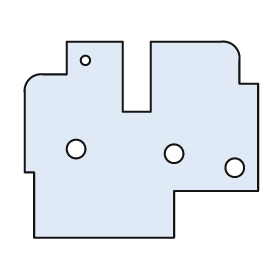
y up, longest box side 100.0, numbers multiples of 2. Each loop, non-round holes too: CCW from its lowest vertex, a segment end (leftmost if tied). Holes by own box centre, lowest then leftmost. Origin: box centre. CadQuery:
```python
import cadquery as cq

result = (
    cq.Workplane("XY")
    .moveTo(-46.0, -42.0)
    .lineTo(14.0, -42.0)
    .lineTo(14.0, -22.0)
    .lineTo(50.0, -22.0)
    .lineTo(50.0, 24.0)
    .lineTo(42.0, 24.0)
    .lineTo(42.0, 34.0)
    .threePointArc((40.0, 40.0), (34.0, 42.0))
    .lineTo(4.0, 42.0)
    .lineTo(4.0, 12.0)
    .lineTo(-8.0, 12.0)
    .lineTo(-8.0, 42.0)
    .lineTo(-32.0, 42.0)
    .lineTo(-32.0, 28.0)
    .lineTo(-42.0, 28.0)
    .threePointArc((-48.0, 26.0), (-50.0, 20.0))
    .lineTo(-50.0, -14.0)
    .lineTo(-46.0, -14.0)
    .close()
    .moveTo(40.0, -12.0)
    .circle(4.0)
    .moveTo(14.0, -6.0)
    .circle(4.0)
    .moveTo(-28.0, -4.0)
    .circle(4.0)
    .moveTo(-24.0, 34.0)
    .circle(2.0)
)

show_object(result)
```